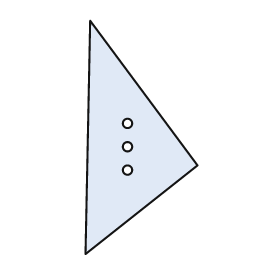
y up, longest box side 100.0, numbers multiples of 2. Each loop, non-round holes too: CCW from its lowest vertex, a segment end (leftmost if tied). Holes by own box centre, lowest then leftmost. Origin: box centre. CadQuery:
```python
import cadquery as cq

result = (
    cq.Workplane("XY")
    .moveTo(-24.0, -50.0)
    .lineTo(24.0, -12.0)
    .lineTo(-22.0, 50.0)
    .close()
    .moveTo(-6.0, -14.0)
    .circle(2.0)
    .moveTo(-6.0, -4.0)
    .circle(2.0)
    .moveTo(-6.0, 6.0)
    .circle(2.0)
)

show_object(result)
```